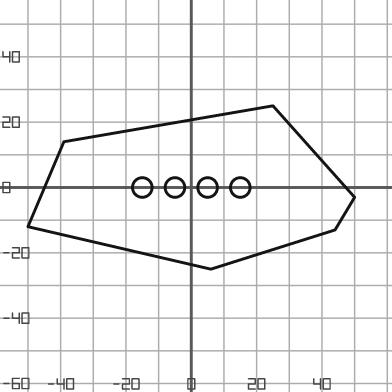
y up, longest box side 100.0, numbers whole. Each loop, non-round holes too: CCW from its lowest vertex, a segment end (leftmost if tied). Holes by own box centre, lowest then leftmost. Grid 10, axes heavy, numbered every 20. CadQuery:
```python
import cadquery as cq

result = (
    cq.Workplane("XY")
    .moveTo(6.0, -25.0)
    .lineTo(44.0, -13.0)
    .lineTo(50.0, -3.0)
    .lineTo(25.0, 25.0)
    .lineTo(-39.0, 14.0)
    .lineTo(-50.0, -12.0)
    .close()
    .moveTo(-15.0, 0.0)
    .circle(3.0)
    .moveTo(-5.0, 0.0)
    .circle(3.0)
    .moveTo(5.0, 0.0)
    .circle(3.0)
    .moveTo(15.0, 0.0)
    .circle(3.0)
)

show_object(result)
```